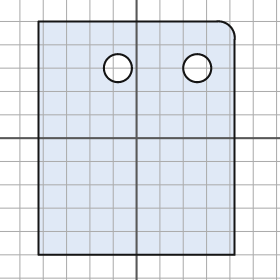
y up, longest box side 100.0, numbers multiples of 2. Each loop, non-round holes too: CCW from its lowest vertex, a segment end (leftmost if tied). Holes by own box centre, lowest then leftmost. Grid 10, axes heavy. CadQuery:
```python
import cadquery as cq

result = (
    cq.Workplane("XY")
    .moveTo(-42.0, -50.0)
    .lineTo(42.0, -50.0)
    .lineTo(42.0, 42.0)
    .threePointArc((40.0, 48.0), (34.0, 50.0))
    .lineTo(-42.0, 50.0)
    .close()
    .moveTo(-8.0, 30.0)
    .circle(6.0)
    .moveTo(26.0, 30.0)
    .circle(6.0)
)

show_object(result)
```